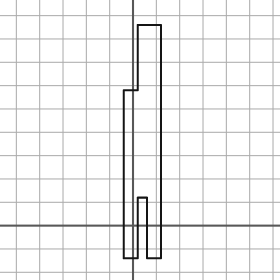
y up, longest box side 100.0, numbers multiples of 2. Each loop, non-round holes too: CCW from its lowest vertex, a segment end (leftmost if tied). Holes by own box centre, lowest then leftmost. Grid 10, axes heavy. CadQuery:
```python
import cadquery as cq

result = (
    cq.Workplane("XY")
    .moveTo(-4.0, -14.0)
    .lineTo(2.0, -14.0)
    .lineTo(2.0, 12.0)
    .lineTo(6.0, 12.0)
    .lineTo(6.0, -14.0)
    .lineTo(12.0, -14.0)
    .lineTo(12.0, 86.0)
    .lineTo(2.0, 86.0)
    .lineTo(2.0, 58.0)
    .lineTo(-4.0, 58.0)
    .close()
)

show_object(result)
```